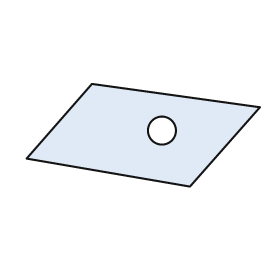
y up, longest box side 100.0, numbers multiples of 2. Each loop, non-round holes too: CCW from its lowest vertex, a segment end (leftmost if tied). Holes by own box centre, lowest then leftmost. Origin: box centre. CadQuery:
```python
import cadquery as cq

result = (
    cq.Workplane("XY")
    .moveTo(20.0, -22.0)
    .lineTo(50.0, 12.0)
    .lineTo(-22.0, 22.0)
    .lineTo(-50.0, -10.0)
    .close()
    .moveTo(8.0, 2.0)
    .circle(6.0)
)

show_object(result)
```